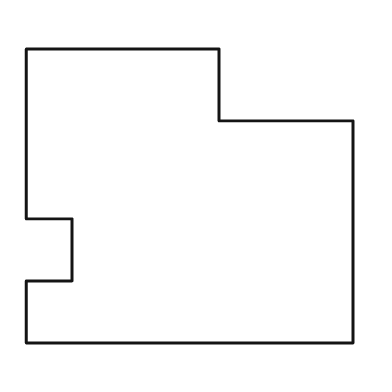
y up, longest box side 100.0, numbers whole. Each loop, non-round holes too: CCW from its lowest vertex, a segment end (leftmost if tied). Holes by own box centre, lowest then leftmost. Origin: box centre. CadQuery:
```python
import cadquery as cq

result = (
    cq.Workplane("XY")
    .moveTo(-50.0, -45.0)
    .lineTo(50.0, -45.0)
    .lineTo(50.0, 23.0)
    .lineTo(9.0, 23.0)
    .lineTo(9.0, 45.0)
    .lineTo(-50.0, 45.0)
    .lineTo(-50.0, -7.0)
    .lineTo(-36.0, -7.0)
    .lineTo(-36.0, -26.0)
    .lineTo(-50.0, -26.0)
    .close()
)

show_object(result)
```